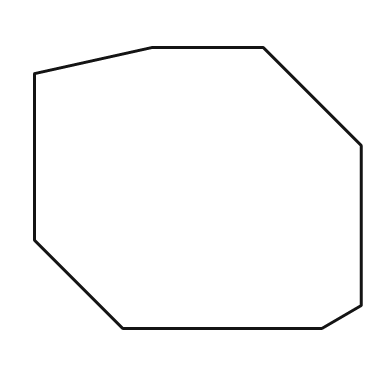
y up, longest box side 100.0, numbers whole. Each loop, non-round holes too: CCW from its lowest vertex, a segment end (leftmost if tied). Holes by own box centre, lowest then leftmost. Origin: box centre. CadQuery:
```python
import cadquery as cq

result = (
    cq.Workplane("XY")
    .moveTo(-23.0, -43.0)
    .lineTo(38.0, -43.0)
    .lineTo(50.0, -36.0)
    .lineTo(50.0, 13.0)
    .lineTo(20.0, 43.0)
    .lineTo(-14.0, 43.0)
    .lineTo(-50.0, 35.0)
    .lineTo(-50.0, -16.0)
    .close()
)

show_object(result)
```